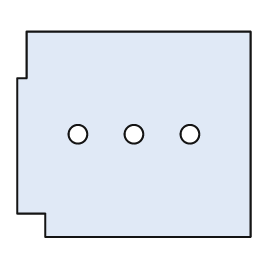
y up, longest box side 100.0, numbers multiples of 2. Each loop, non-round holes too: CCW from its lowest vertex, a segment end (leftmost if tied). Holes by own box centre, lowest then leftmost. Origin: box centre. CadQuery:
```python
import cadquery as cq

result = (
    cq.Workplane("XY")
    .moveTo(-38.0, -44.0)
    .lineTo(50.0, -44.0)
    .lineTo(50.0, 44.0)
    .lineTo(-46.0, 44.0)
    .lineTo(-46.0, 24.0)
    .lineTo(-50.0, 24.0)
    .lineTo(-50.0, -34.0)
    .lineTo(-38.0, -34.0)
    .close()
    .moveTo(-24.0, 0.0)
    .circle(4.0)
    .moveTo(0.0, 0.0)
    .circle(4.0)
    .moveTo(24.0, 0.0)
    .circle(4.0)
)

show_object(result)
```